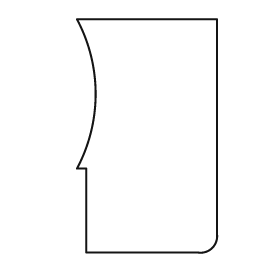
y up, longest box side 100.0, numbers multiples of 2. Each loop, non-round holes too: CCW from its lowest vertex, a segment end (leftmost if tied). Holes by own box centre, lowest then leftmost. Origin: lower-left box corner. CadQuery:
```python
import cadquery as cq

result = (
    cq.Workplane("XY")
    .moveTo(4.0, 0.0)
    .lineTo(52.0, 0.0)
    .threePointArc((58.0, 2.0), (60.0, 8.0))
    .lineTo(60.0, 100.0)
    .lineTo(0.0, 100.0)
    .threePointArc((8.0, 68.0), (0.0, 36.0))
    .lineTo(4.0, 36.0)
    .close()
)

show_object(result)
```